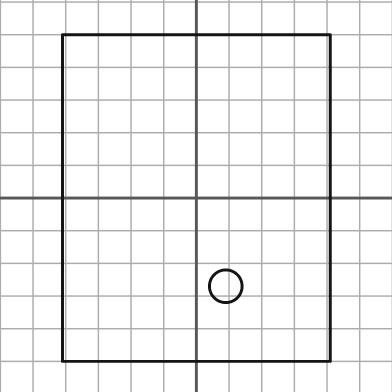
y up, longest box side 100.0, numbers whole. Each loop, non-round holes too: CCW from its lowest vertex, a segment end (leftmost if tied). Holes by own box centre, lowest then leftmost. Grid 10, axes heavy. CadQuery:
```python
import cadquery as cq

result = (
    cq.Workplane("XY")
    .moveTo(-41.0, -50.0)
    .lineTo(41.0, -50.0)
    .lineTo(41.0, 50.0)
    .lineTo(-41.0, 50.0)
    .close()
    .moveTo(9.0, -27.0)
    .circle(5.0)
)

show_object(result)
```